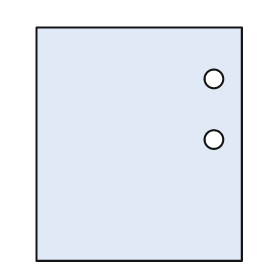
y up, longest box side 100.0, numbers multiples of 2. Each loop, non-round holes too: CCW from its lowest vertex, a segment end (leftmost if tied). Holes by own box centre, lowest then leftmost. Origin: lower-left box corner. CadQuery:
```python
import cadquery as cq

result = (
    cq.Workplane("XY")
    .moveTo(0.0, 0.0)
    .lineTo(88.0, 0.0)
    .lineTo(88.0, 100.0)
    .lineTo(0.0, 100.0)
    .close()
    .moveTo(76.0, 52.0)
    .circle(4.0)
    .moveTo(76.0, 78.0)
    .circle(4.0)
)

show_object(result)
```